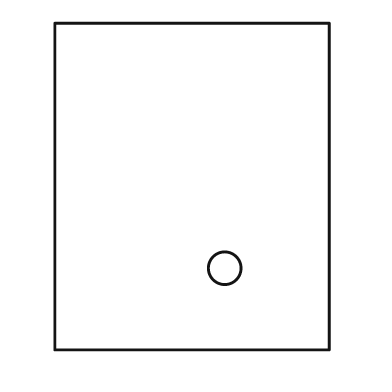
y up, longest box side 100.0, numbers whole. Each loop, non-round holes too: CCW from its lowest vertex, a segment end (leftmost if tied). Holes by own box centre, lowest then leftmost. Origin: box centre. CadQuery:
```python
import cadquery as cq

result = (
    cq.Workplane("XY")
    .moveTo(-42.0, -50.0)
    .lineTo(42.0, -50.0)
    .lineTo(42.0, 50.0)
    .lineTo(-42.0, 50.0)
    .close()
    .moveTo(10.0, -25.0)
    .circle(5.0)
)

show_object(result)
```